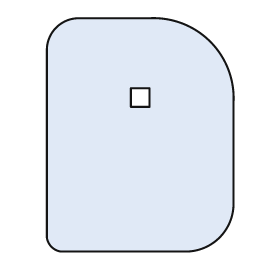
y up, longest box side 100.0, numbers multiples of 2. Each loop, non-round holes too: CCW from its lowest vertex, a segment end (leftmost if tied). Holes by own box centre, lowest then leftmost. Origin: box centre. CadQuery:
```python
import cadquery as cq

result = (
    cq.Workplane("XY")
    .moveTo(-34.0, -50.0)
    .lineTo(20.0, -50.0)
    .threePointArc((34.0, -44.0), (40.0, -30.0))
    .lineTo(40.0, 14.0)
    .threePointArc((30.0, 40.0), (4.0, 50.0))
    .lineTo(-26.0, 50.0)
    .threePointArc((-36.0, 46.0), (-40.0, 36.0))
    .lineTo(-40.0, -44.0)
    .threePointArc((-38.0, -48.0), (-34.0, -50.0))
    .close()
    .moveTo(-4.0, 12.0)
    .lineTo(4.0, 12.0)
    .lineTo(4.0, 20.0)
    .lineTo(-4.0, 20.0)
    .close()
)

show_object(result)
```